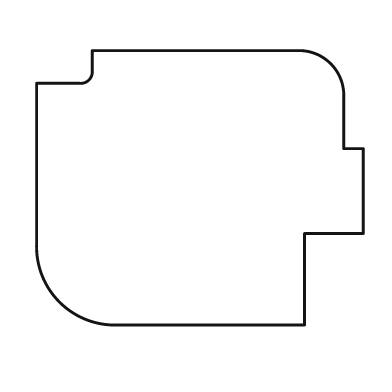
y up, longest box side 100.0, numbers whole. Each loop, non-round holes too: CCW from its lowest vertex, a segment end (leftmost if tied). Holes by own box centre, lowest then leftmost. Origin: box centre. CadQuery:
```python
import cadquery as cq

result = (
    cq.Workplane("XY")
    .moveTo(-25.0, -42.0)
    .lineTo(32.0, -42.0)
    .lineTo(32.0, -14.0)
    .lineTo(50.0, -14.0)
    .lineTo(50.0, 12.0)
    .lineTo(44.0, 12.0)
    .lineTo(44.0, 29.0)
    .threePointArc((40.0, 38.0), (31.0, 42.0))
    .lineTo(-33.0, 42.0)
    .lineTo(-33.0, 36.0)
    .threePointArc((-34.0, 33.0), (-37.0, 32.0))
    .lineTo(-50.0, 32.0)
    .lineTo(-50.0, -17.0)
    .threePointArc((-43.0, -35.0), (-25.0, -42.0))
    .close()
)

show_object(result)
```